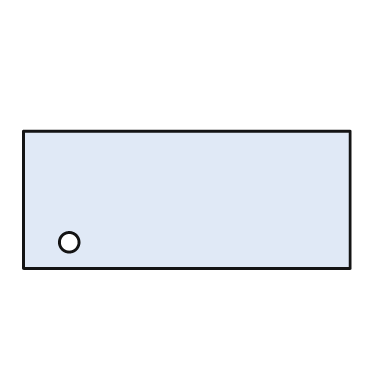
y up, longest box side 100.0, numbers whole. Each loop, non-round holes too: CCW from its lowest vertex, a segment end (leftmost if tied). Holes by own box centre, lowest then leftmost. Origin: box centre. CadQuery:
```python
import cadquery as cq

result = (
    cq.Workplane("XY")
    .moveTo(-50.0, -21.0)
    .lineTo(50.0, -21.0)
    .lineTo(50.0, 21.0)
    .lineTo(-50.0, 21.0)
    .close()
    .moveTo(-36.0, -13.0)
    .circle(3.0)
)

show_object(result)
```